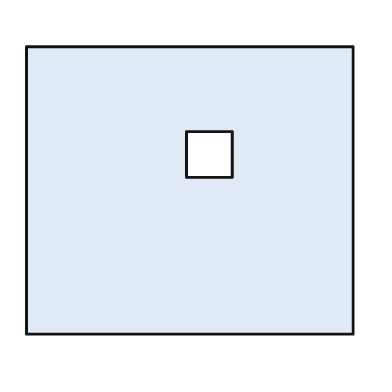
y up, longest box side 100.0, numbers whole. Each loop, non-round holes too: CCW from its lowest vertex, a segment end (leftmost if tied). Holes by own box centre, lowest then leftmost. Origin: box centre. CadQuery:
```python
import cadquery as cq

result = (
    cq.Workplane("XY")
    .moveTo(-50.0, -44.0)
    .lineTo(50.0, -44.0)
    .lineTo(50.0, 44.0)
    .lineTo(-50.0, 44.0)
    .close()
    .moveTo(-1.0, 4.0)
    .lineTo(13.0, 4.0)
    .lineTo(13.0, 18.0)
    .lineTo(-1.0, 18.0)
    .close()
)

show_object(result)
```